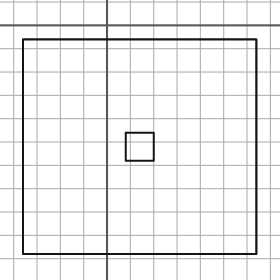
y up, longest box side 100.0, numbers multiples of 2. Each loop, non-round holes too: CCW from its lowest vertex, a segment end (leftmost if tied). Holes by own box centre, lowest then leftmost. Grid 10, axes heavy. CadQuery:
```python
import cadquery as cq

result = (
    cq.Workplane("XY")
    .moveTo(-36.0, -98.0)
    .lineTo(64.0, -98.0)
    .lineTo(64.0, -6.0)
    .lineTo(-36.0, -6.0)
    .close()
    .moveTo(8.0, -58.0)
    .lineTo(20.0, -58.0)
    .lineTo(20.0, -46.0)
    .lineTo(8.0, -46.0)
    .close()
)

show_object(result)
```